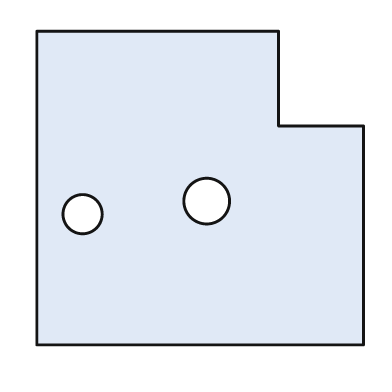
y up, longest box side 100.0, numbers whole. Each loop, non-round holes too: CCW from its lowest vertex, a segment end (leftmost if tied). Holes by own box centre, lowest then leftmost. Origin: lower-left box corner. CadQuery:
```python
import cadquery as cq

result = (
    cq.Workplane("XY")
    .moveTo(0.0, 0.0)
    .lineTo(100.0, 0.0)
    .lineTo(100.0, 67.0)
    .lineTo(74.0, 67.0)
    .lineTo(74.0, 96.0)
    .lineTo(0.0, 96.0)
    .close()
    .moveTo(14.0, 40.0)
    .circle(6.0)
    .moveTo(52.0, 44.0)
    .circle(7.0)
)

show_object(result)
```